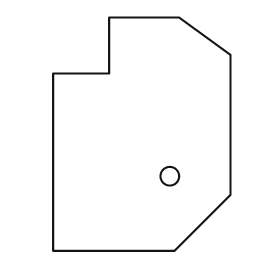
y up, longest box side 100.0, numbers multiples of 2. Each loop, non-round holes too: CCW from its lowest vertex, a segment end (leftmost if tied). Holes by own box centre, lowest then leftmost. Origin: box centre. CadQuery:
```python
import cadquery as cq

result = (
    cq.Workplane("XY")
    .moveTo(-38.0, -50.0)
    .lineTo(14.0, -50.0)
    .lineTo(38.0, -26.0)
    .lineTo(38.0, 34.0)
    .lineTo(16.0, 50.0)
    .lineTo(-14.0, 50.0)
    .lineTo(-14.0, 26.0)
    .lineTo(-38.0, 26.0)
    .close()
    .moveTo(12.0, -18.0)
    .circle(4.0)
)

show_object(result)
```